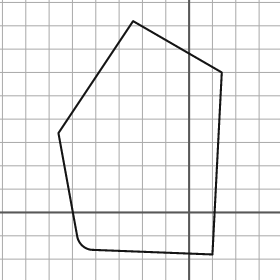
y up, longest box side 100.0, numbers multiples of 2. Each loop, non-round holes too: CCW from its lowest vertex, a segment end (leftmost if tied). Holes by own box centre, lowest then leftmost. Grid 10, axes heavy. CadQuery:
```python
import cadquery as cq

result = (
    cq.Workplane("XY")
    .moveTo(10.0, -18.0)
    .lineTo(14.0, 60.0)
    .lineTo(-24.0, 82.0)
    .lineTo(-56.0, 34.0)
    .lineTo(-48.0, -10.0)
    .threePointArc((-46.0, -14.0), (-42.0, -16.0))
    .close()
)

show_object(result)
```